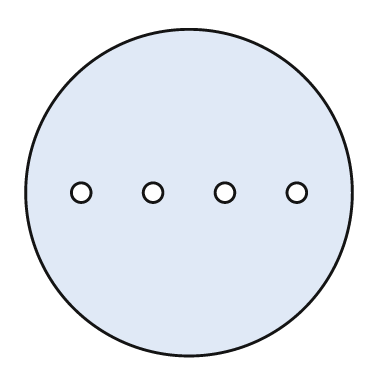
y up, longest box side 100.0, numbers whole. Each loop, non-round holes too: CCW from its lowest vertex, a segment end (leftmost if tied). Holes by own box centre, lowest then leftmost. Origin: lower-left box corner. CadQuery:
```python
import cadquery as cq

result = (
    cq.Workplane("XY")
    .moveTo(50.0, 50.0)
    .circle(50.0)
    .moveTo(17.0, 50.0)
    .circle(3.0)
    .moveTo(39.0, 50.0)
    .circle(3.0)
    .moveTo(61.0, 50.0)
    .circle(3.0)
    .moveTo(83.0, 50.0)
    .circle(3.0)
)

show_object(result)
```